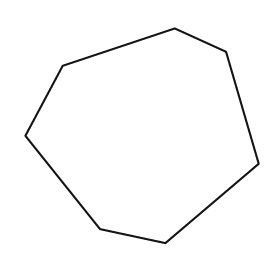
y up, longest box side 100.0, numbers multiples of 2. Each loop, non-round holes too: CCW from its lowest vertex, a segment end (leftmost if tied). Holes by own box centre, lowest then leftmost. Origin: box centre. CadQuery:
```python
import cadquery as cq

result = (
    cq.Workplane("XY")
    .moveTo(10.0, -46.0)
    .lineTo(50.0, -12.0)
    .lineTo(36.0, 36.0)
    .lineTo(14.0, 46.0)
    .lineTo(-34.0, 30.0)
    .lineTo(-50.0, 0.0)
    .lineTo(-18.0, -40.0)
    .close()
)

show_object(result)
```